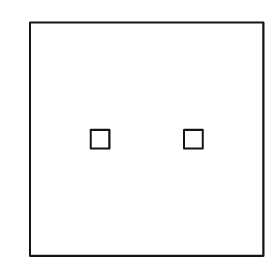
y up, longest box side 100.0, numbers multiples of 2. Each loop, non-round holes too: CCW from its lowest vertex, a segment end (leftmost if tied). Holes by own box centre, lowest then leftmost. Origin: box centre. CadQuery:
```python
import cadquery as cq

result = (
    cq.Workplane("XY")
    .moveTo(-50.0, -50.0)
    .lineTo(50.0, -50.0)
    .lineTo(50.0, 50.0)
    .lineTo(-50.0, 50.0)
    .close()
    .moveTo(-24.0, -4.0)
    .lineTo(-16.0, -4.0)
    .lineTo(-16.0, 4.0)
    .lineTo(-24.0, 4.0)
    .close()
    .moveTo(16.0, -4.0)
    .lineTo(24.0, -4.0)
    .lineTo(24.0, 4.0)
    .lineTo(16.0, 4.0)
    .close()
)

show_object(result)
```